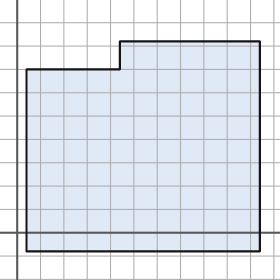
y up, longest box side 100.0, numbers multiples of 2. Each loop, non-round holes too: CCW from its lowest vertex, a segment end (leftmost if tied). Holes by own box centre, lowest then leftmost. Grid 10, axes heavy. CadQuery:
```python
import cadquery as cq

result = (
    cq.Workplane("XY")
    .moveTo(4.0, -8.0)
    .lineTo(104.0, -8.0)
    .lineTo(104.0, 82.0)
    .lineTo(44.0, 82.0)
    .lineTo(44.0, 70.0)
    .lineTo(4.0, 70.0)
    .close()
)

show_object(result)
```